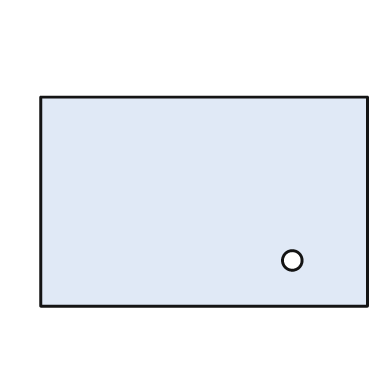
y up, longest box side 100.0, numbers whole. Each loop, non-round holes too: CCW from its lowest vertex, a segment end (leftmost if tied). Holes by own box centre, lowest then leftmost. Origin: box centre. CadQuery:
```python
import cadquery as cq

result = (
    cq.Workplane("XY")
    .moveTo(-50.0, -32.0)
    .lineTo(50.0, -32.0)
    .lineTo(50.0, 32.0)
    .lineTo(-50.0, 32.0)
    .close()
    .moveTo(27.0, -18.0)
    .circle(3.0)
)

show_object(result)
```